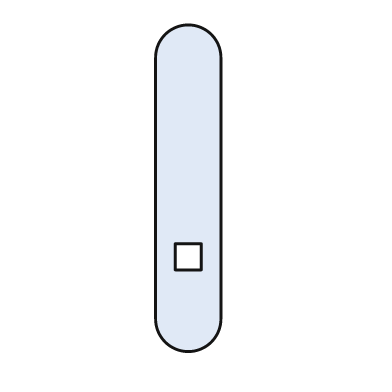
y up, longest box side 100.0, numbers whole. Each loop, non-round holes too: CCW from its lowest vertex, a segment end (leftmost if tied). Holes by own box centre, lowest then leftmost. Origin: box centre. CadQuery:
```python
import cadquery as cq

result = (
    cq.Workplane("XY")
    .moveTo(-10.0, -40.0)
    .threePointArc((0.0, -50.0), (10.0, -40.0))
    .lineTo(10.0, 40.0)
    .threePointArc((0.0, 50.0), (-10.0, 40.0))
    .close()
    .moveTo(-4.0, -25.0)
    .lineTo(4.0, -25.0)
    .lineTo(4.0, -17.0)
    .lineTo(-4.0, -17.0)
    .close()
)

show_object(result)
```